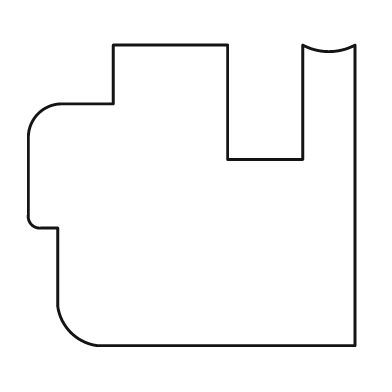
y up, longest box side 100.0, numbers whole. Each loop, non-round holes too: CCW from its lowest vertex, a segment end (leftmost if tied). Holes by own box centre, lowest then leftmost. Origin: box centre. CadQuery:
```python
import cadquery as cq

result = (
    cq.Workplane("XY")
    .moveTo(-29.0, -46.0)
    .lineTo(50.0, -46.0)
    .lineTo(50.0, 46.0)
    .threePointArc((42.0, 44.0), (34.0, 46.0))
    .lineTo(34.0, 11.0)
    .lineTo(11.0, 11.0)
    .lineTo(11.0, 46.0)
    .lineTo(-24.0, 46.0)
    .lineTo(-24.0, 28.0)
    .lineTo(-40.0, 28.0)
    .threePointArc((-47.0, 25.0), (-50.0, 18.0))
    .lineTo(-50.0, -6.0)
    .threePointArc((-49.0, -9.0), (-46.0, -10.0))
    .lineTo(-41.0, -10.0)
    .lineTo(-41.0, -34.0)
    .threePointArc((-37.0, -42.0), (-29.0, -46.0))
    .close()
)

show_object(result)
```